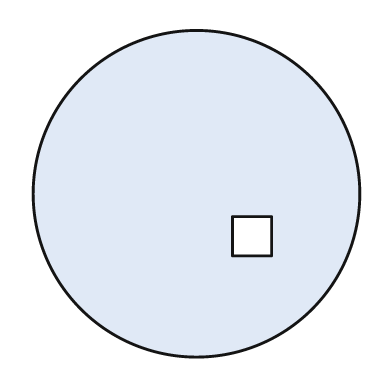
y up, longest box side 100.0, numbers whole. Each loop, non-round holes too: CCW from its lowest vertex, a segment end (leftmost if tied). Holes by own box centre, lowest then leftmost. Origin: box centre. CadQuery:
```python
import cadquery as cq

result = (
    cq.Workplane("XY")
    .moveTo(0.0, 0.0)
    .circle(50.0)
    .moveTo(11.0, -19.0)
    .lineTo(23.0, -19.0)
    .lineTo(23.0, -7.0)
    .lineTo(11.0, -7.0)
    .close()
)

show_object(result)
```